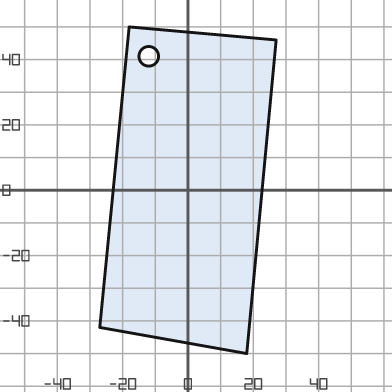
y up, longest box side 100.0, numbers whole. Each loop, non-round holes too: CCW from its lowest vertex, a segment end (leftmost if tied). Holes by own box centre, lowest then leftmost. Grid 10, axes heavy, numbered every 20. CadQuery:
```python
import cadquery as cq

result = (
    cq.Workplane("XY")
    .moveTo(18.0, -50.0)
    .lineTo(27.0, 46.0)
    .lineTo(-18.0, 50.0)
    .lineTo(-27.0, -42.0)
    .close()
    .moveTo(-12.0, 41.0)
    .circle(3.0)
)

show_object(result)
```